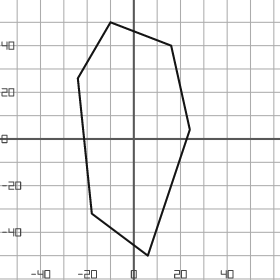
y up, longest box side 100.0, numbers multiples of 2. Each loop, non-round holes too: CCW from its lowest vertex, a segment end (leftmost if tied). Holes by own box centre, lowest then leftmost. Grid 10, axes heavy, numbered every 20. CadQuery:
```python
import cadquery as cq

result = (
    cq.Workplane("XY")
    .moveTo(6.0, -50.0)
    .lineTo(24.0, 4.0)
    .lineTo(16.0, 40.0)
    .lineTo(-10.0, 50.0)
    .lineTo(-24.0, 26.0)
    .lineTo(-18.0, -32.0)
    .close()
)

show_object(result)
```